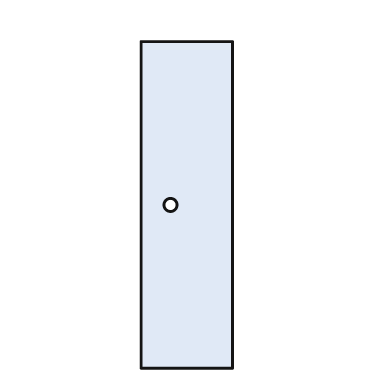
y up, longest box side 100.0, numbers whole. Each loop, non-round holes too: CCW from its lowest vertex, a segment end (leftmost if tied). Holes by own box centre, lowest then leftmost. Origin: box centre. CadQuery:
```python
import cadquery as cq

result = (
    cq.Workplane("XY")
    .moveTo(-14.0, -50.0)
    .lineTo(14.0, -50.0)
    .lineTo(14.0, 50.0)
    .lineTo(-14.0, 50.0)
    .close()
    .moveTo(-5.0, 0.0)
    .circle(2.0)
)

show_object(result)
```